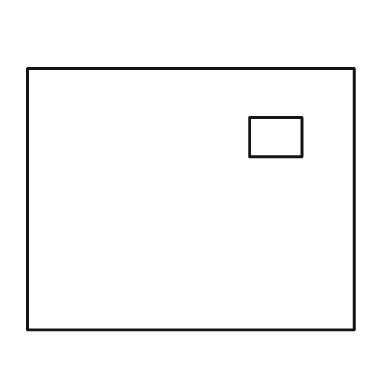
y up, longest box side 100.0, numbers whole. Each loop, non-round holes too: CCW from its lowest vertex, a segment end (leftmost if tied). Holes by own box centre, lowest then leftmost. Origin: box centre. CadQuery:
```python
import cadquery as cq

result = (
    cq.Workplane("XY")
    .moveTo(-50.0, -40.0)
    .lineTo(50.0, -40.0)
    .lineTo(50.0, 40.0)
    .lineTo(-50.0, 40.0)
    .close()
    .moveTo(18.0, 13.0)
    .lineTo(34.0, 13.0)
    .lineTo(34.0, 25.0)
    .lineTo(18.0, 25.0)
    .close()
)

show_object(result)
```